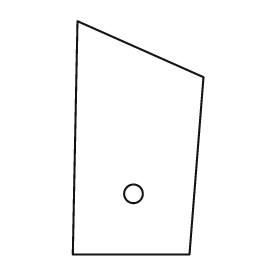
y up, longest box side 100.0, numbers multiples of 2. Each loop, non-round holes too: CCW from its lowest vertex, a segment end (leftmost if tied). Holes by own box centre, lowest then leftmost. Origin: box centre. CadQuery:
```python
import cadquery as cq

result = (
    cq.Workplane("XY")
    .moveTo(-28.0, -50.0)
    .lineTo(22.0, -50.0)
    .lineTo(28.0, 26.0)
    .lineTo(-26.0, 50.0)
    .close()
    .moveTo(-2.0, -24.0)
    .circle(4.0)
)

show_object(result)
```